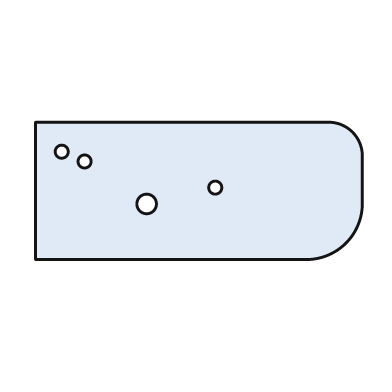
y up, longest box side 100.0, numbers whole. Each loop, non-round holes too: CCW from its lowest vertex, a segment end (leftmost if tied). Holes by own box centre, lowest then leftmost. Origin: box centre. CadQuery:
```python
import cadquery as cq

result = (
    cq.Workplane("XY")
    .moveTo(-50.0, -21.0)
    .lineTo(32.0, -21.0)
    .threePointArc((45.0, -16.0), (50.0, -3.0))
    .lineTo(50.0, 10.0)
    .threePointArc((47.0, 18.0), (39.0, 21.0))
    .lineTo(-50.0, 21.0)
    .close()
    .moveTo(-16.0, -4.0)
    .circle(3.0)
    .moveTo(5.0, 1.0)
    .circle(2.0)
    .moveTo(-35.0, 9.0)
    .circle(2.0)
    .moveTo(-42.0, 12.0)
    .circle(2.0)
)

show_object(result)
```